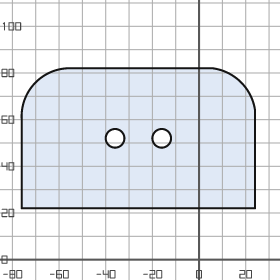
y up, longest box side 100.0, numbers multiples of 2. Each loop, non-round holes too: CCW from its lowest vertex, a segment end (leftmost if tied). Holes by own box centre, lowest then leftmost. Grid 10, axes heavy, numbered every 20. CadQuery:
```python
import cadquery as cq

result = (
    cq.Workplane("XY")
    .moveTo(-76.0, 22.0)
    .lineTo(24.0, 22.0)
    .lineTo(24.0, 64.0)
    .threePointArc((18.0, 76.0), (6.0, 82.0))
    .lineTo(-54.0, 82.0)
    .threePointArc((-70.0, 76.0), (-76.0, 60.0))
    .close()
    .moveTo(-36.0, 52.0)
    .circle(4.0)
    .moveTo(-16.0, 52.0)
    .circle(4.0)
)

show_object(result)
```